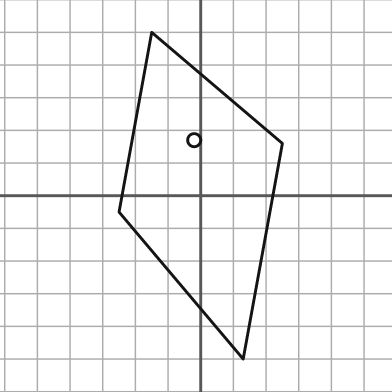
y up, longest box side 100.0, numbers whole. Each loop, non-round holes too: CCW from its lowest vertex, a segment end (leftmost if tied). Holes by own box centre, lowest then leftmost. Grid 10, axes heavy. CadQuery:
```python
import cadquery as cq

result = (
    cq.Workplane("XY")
    .moveTo(13.0, -50.0)
    .lineTo(25.0, 16.0)
    .lineTo(-15.0, 50.0)
    .lineTo(-25.0, -5.0)
    .close()
    .moveTo(-2.0, 17.0)
    .circle(2.0)
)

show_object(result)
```